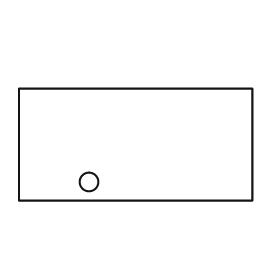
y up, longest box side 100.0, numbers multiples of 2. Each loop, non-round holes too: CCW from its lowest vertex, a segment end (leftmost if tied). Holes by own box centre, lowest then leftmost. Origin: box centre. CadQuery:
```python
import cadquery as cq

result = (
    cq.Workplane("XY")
    .moveTo(-50.0, -24.0)
    .lineTo(50.0, -24.0)
    .lineTo(50.0, 24.0)
    .lineTo(-50.0, 24.0)
    .close()
    .moveTo(-20.0, -16.0)
    .circle(4.0)
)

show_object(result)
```